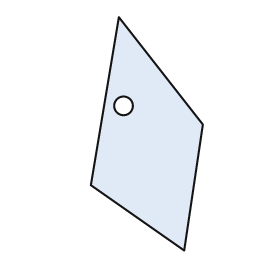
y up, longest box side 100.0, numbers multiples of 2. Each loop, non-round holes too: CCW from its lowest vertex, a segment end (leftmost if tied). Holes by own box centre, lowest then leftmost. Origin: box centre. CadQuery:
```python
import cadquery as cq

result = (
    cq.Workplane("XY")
    .moveTo(16.0, -50.0)
    .lineTo(24.0, 4.0)
    .lineTo(-12.0, 50.0)
    .lineTo(-24.0, -22.0)
    .close()
    .moveTo(-10.0, 12.0)
    .circle(4.0)
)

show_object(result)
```